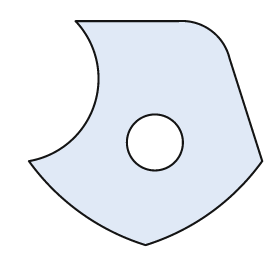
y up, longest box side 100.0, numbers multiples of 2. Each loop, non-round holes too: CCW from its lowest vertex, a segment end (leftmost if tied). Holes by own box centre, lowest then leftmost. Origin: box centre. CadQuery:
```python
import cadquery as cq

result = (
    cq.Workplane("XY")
    .moveTo(0.0, -48.0)
    .threePointArc((28.0, -34.0), (50.0, -12.0))
    .lineTo(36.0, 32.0)
    .threePointArc((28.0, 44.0), (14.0, 48.0))
    .lineTo(-30.0, 48.0)
    .threePointArc((-22.0, 12.0), (-50.0, -12.0))
    .threePointArc((-28.0, -34.0), (0.0, -48.0))
    .close()
    .moveTo(4.0, -4.0)
    .circle(12.0)
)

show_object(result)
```